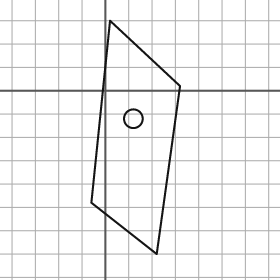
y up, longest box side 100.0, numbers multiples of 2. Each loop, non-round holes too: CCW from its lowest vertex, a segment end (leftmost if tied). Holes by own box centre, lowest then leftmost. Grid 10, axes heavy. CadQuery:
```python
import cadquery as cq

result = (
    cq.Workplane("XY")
    .moveTo(22.0, -70.0)
    .lineTo(32.0, 2.0)
    .lineTo(2.0, 30.0)
    .lineTo(-6.0, -48.0)
    .close()
    .moveTo(12.0, -12.0)
    .circle(4.0)
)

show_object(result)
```